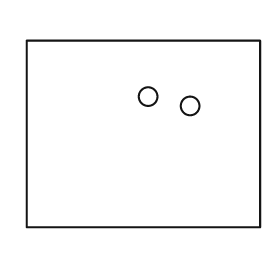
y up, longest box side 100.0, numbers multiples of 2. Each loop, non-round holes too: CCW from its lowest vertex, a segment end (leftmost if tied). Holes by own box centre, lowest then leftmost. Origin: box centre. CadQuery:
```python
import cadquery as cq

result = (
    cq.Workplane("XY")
    .moveTo(-50.0, -40.0)
    .lineTo(50.0, -40.0)
    .lineTo(50.0, 40.0)
    .lineTo(-50.0, 40.0)
    .close()
    .moveTo(20.0, 12.0)
    .circle(4.0)
    .moveTo(2.0, 16.0)
    .circle(4.0)
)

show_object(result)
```